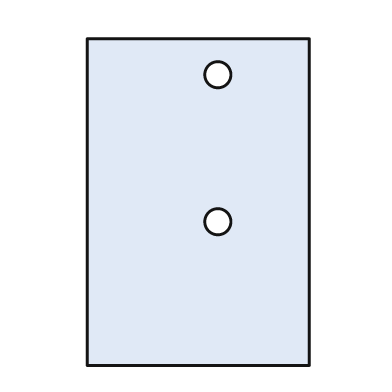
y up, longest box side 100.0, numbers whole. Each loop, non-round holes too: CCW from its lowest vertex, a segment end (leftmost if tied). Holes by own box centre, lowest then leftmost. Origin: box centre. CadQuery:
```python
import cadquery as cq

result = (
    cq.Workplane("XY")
    .moveTo(-34.0, -50.0)
    .lineTo(34.0, -50.0)
    .lineTo(34.0, 50.0)
    .lineTo(-34.0, 50.0)
    .close()
    .moveTo(6.0, -6.0)
    .circle(4.0)
    .moveTo(6.0, 39.0)
    .circle(4.0)
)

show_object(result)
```